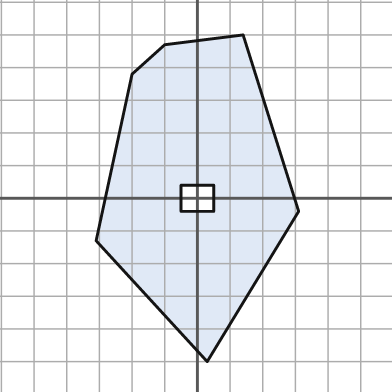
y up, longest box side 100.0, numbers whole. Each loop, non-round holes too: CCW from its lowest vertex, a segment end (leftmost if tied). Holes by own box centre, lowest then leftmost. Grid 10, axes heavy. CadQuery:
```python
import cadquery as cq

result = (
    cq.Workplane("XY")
    .moveTo(3.0, -50.0)
    .lineTo(31.0, -4.0)
    .lineTo(14.0, 50.0)
    .lineTo(-10.0, 47.0)
    .lineTo(-20.0, 38.0)
    .lineTo(-31.0, -13.0)
    .close()
    .moveTo(-5.0, -4.0)
    .lineTo(5.0, -4.0)
    .lineTo(5.0, 4.0)
    .lineTo(-5.0, 4.0)
    .close()
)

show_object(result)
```